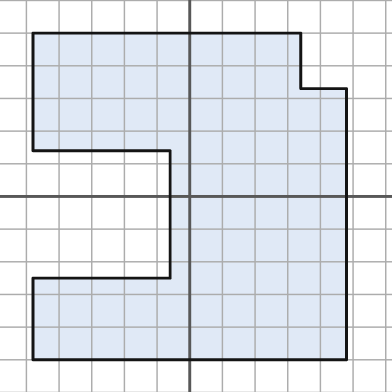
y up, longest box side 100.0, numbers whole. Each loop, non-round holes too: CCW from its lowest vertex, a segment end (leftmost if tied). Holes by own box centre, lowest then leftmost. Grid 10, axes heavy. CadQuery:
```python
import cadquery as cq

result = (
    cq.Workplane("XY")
    .moveTo(-48.0, -50.0)
    .lineTo(48.0, -50.0)
    .lineTo(48.0, 33.0)
    .lineTo(34.0, 33.0)
    .lineTo(34.0, 50.0)
    .lineTo(-48.0, 50.0)
    .lineTo(-48.0, 14.0)
    .lineTo(-6.0, 14.0)
    .lineTo(-6.0, -25.0)
    .lineTo(-48.0, -25.0)
    .close()
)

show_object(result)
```